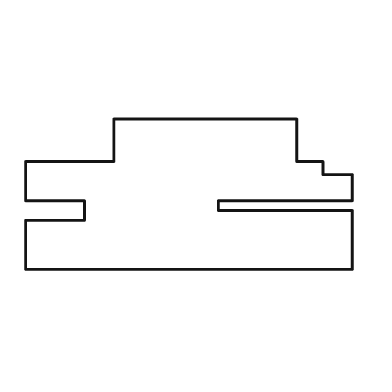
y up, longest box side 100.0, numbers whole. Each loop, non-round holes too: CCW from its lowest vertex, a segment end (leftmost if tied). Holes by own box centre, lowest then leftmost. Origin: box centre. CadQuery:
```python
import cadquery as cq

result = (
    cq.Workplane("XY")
    .moveTo(-50.0, -23.0)
    .lineTo(50.0, -23.0)
    .lineTo(50.0, -5.0)
    .lineTo(9.0, -5.0)
    .lineTo(9.0, -2.0)
    .lineTo(50.0, -2.0)
    .lineTo(50.0, 6.0)
    .lineTo(41.0, 6.0)
    .lineTo(41.0, 10.0)
    .lineTo(33.0, 10.0)
    .lineTo(33.0, 23.0)
    .lineTo(-23.0, 23.0)
    .lineTo(-23.0, 10.0)
    .lineTo(-50.0, 10.0)
    .lineTo(-50.0, -2.0)
    .lineTo(-32.0, -2.0)
    .lineTo(-32.0, -8.0)
    .lineTo(-50.0, -8.0)
    .close()
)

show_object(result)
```